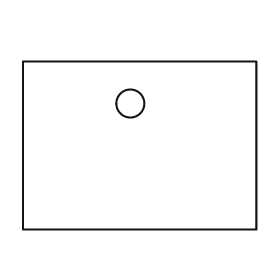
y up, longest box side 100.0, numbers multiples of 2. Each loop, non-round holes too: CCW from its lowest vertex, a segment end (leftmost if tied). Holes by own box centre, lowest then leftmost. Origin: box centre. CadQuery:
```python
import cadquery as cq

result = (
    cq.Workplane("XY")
    .moveTo(-50.0, -36.0)
    .lineTo(50.0, -36.0)
    .lineTo(50.0, 36.0)
    .lineTo(-50.0, 36.0)
    .close()
    .moveTo(-4.0, 18.0)
    .circle(6.0)
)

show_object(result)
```